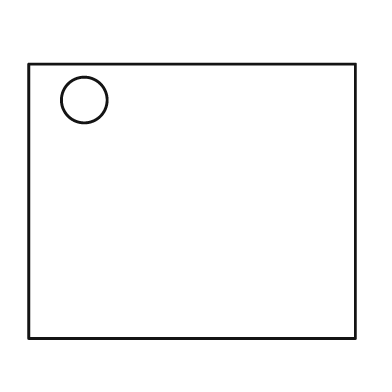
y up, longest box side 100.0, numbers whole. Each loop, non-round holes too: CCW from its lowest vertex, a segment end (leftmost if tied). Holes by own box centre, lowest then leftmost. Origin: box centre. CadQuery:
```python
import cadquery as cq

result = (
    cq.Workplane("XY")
    .moveTo(-50.0, -42.0)
    .lineTo(50.0, -42.0)
    .lineTo(50.0, 42.0)
    .lineTo(-50.0, 42.0)
    .close()
    .moveTo(-33.0, 31.0)
    .circle(7.0)
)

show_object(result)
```